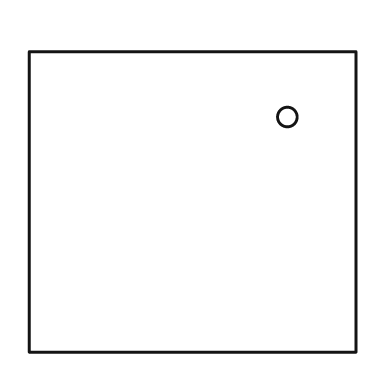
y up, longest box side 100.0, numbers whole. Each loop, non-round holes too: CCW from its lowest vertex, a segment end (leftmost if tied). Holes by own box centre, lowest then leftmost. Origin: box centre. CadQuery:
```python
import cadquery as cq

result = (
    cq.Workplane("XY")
    .moveTo(-50.0, -46.0)
    .lineTo(50.0, -46.0)
    .lineTo(50.0, 46.0)
    .lineTo(-50.0, 46.0)
    .close()
    .moveTo(29.0, 26.0)
    .circle(3.0)
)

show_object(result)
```